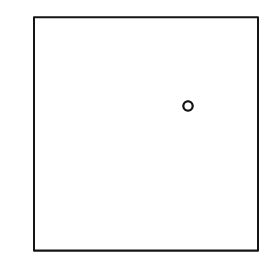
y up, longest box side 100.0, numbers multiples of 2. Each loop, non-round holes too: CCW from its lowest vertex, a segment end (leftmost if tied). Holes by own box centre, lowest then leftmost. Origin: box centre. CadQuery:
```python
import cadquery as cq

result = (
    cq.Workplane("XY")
    .moveTo(-48.0, -50.0)
    .lineTo(48.0, -50.0)
    .lineTo(48.0, 50.0)
    .lineTo(-48.0, 50.0)
    .close()
    .moveTo(18.0, 12.0)
    .circle(2.0)
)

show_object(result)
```